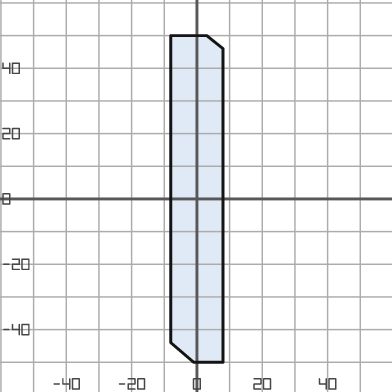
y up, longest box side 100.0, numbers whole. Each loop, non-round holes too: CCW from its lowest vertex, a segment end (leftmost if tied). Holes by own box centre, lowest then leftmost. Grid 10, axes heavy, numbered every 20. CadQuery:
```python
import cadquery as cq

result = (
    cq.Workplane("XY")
    .moveTo(-1.0, -50.0)
    .lineTo(8.0, -50.0)
    .lineTo(8.0, 46.0)
    .lineTo(3.0, 50.0)
    .lineTo(-8.0, 50.0)
    .lineTo(-8.0, -44.0)
    .close()
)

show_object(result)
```